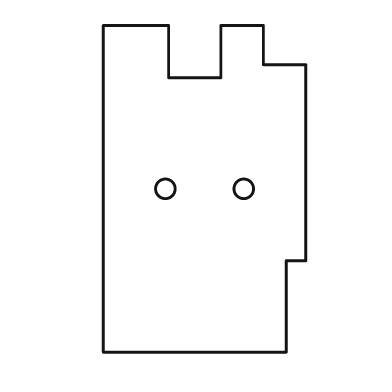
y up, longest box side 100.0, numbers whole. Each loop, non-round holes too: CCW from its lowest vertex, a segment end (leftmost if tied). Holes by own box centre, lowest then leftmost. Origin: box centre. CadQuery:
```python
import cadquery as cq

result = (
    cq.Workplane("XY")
    .moveTo(-31.0, -50.0)
    .lineTo(25.0, -50.0)
    .lineTo(25.0, -22.0)
    .lineTo(31.0, -22.0)
    .lineTo(31.0, 38.0)
    .lineTo(18.0, 38.0)
    .lineTo(18.0, 50.0)
    .lineTo(5.0, 50.0)
    .lineTo(5.0, 34.0)
    .lineTo(-11.0, 34.0)
    .lineTo(-11.0, 50.0)
    .lineTo(-31.0, 50.0)
    .close()
    .moveTo(-12.0, 0.0)
    .circle(3.0)
    .moveTo(12.0, 0.0)
    .circle(3.0)
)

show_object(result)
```